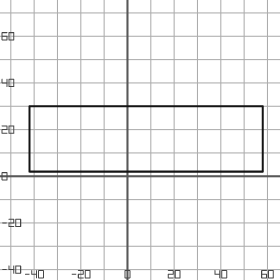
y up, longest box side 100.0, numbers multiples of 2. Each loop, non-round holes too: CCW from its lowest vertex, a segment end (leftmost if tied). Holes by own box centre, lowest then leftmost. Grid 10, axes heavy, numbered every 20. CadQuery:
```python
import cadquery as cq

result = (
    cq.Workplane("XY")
    .moveTo(-42.0, 2.0)
    .lineTo(58.0, 2.0)
    .lineTo(58.0, 30.0)
    .lineTo(-42.0, 30.0)
    .close()
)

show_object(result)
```